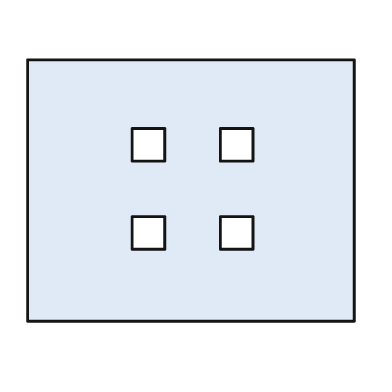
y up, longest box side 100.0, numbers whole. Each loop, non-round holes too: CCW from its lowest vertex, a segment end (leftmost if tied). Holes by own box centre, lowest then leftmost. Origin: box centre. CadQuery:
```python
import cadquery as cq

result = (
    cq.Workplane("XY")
    .moveTo(-50.0, -40.0)
    .lineTo(50.0, -40.0)
    .lineTo(50.0, 40.0)
    .lineTo(-50.0, 40.0)
    .close()
    .moveTo(-18.0, -18.0)
    .lineTo(-8.0, -18.0)
    .lineTo(-8.0, -8.0)
    .lineTo(-18.0, -8.0)
    .close()
    .moveTo(9.0, -18.0)
    .lineTo(19.0, -18.0)
    .lineTo(19.0, -8.0)
    .lineTo(9.0, -8.0)
    .close()
    .moveTo(-18.0, 9.0)
    .lineTo(-8.0, 9.0)
    .lineTo(-8.0, 19.0)
    .lineTo(-18.0, 19.0)
    .close()
    .moveTo(9.0, 9.0)
    .lineTo(19.0, 9.0)
    .lineTo(19.0, 19.0)
    .lineTo(9.0, 19.0)
    .close()
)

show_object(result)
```